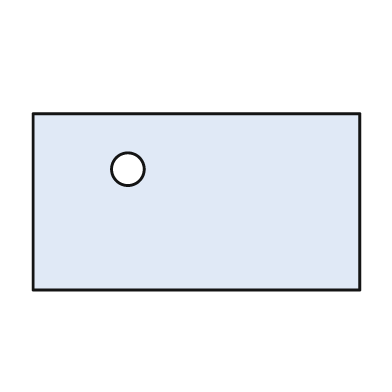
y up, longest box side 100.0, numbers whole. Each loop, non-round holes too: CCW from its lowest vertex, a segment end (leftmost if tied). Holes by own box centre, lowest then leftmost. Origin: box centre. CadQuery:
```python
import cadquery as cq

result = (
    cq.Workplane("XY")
    .moveTo(-50.0, -27.0)
    .lineTo(50.0, -27.0)
    .lineTo(50.0, 27.0)
    .lineTo(-50.0, 27.0)
    .close()
    .moveTo(-21.0, 10.0)
    .circle(5.0)
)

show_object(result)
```